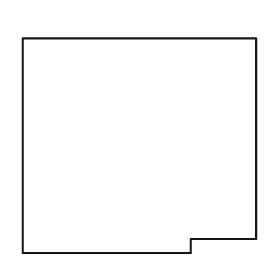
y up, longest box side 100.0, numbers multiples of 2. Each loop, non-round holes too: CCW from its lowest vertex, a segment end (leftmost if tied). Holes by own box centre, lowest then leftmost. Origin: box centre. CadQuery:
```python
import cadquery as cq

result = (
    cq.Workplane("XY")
    .moveTo(-50.0, -46.0)
    .lineTo(22.0, -46.0)
    .lineTo(22.0, -40.0)
    .lineTo(50.0, -40.0)
    .lineTo(50.0, 46.0)
    .lineTo(-50.0, 46.0)
    .close()
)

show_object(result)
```